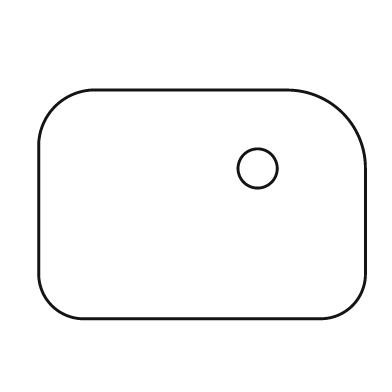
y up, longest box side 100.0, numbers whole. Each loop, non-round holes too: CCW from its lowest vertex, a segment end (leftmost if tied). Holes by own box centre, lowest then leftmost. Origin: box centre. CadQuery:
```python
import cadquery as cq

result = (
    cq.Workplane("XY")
    .moveTo(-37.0, -35.0)
    .lineTo(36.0, -35.0)
    .threePointArc((46.0, -31.0), (50.0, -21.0))
    .lineTo(50.0, 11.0)
    .threePointArc((43.0, 28.0), (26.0, 35.0))
    .lineTo(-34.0, 35.0)
    .threePointArc((-45.0, 30.0), (-50.0, 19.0))
    .lineTo(-50.0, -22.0)
    .threePointArc((-46.0, -31.0), (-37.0, -35.0))
    .close()
    .moveTo(17.0, 11.0)
    .circle(6.0)
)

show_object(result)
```